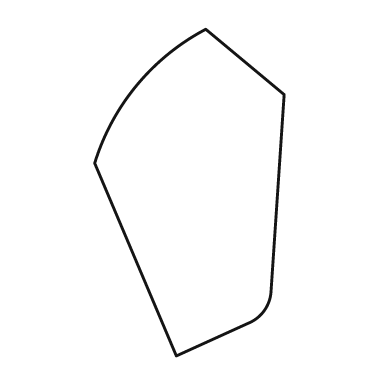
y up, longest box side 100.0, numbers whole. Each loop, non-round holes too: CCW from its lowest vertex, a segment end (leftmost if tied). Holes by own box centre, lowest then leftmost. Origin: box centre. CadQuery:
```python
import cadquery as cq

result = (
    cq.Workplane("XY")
    .moveTo(-4.0, -50.0)
    .lineTo(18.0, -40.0)
    .threePointArc((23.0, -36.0), (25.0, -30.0))
    .lineTo(29.0, 30.0)
    .lineTo(5.0, 50.0)
    .threePointArc((-16.0, 33.0), (-29.0, 9.0))
    .close()
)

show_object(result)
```